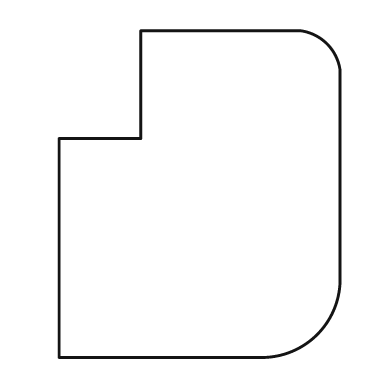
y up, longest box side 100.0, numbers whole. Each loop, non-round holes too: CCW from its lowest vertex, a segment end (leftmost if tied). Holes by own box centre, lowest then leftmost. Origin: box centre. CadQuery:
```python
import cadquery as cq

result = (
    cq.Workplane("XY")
    .moveTo(-43.0, -50.0)
    .lineTo(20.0, -50.0)
    .threePointArc((36.0, -43.0), (43.0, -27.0))
    .lineTo(43.0, 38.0)
    .threePointArc((39.0, 46.0), (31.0, 50.0))
    .lineTo(-18.0, 50.0)
    .lineTo(-18.0, 17.0)
    .lineTo(-43.0, 17.0)
    .close()
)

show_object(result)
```